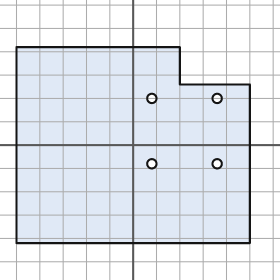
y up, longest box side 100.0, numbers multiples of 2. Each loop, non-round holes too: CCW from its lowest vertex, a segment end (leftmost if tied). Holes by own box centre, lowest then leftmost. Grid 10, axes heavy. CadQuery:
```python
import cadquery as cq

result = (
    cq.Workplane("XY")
    .moveTo(-50.0, -42.0)
    .lineTo(50.0, -42.0)
    .lineTo(50.0, 26.0)
    .lineTo(20.0, 26.0)
    .lineTo(20.0, 42.0)
    .lineTo(-50.0, 42.0)
    .close()
    .moveTo(8.0, -8.0)
    .circle(2.0)
    .moveTo(36.0, -8.0)
    .circle(2.0)
    .moveTo(8.0, 20.0)
    .circle(2.0)
    .moveTo(36.0, 20.0)
    .circle(2.0)
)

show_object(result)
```